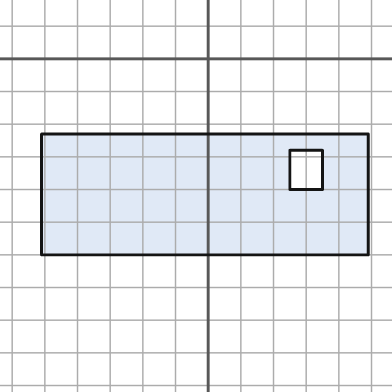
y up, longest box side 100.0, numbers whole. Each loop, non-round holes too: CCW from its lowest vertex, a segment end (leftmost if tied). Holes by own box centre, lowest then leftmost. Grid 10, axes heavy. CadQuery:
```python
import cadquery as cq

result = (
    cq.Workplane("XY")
    .moveTo(-51.0, -60.0)
    .lineTo(49.0, -60.0)
    .lineTo(49.0, -23.0)
    .lineTo(-51.0, -23.0)
    .close()
    .moveTo(25.0, -40.0)
    .lineTo(35.0, -40.0)
    .lineTo(35.0, -28.0)
    .lineTo(25.0, -28.0)
    .close()
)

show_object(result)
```